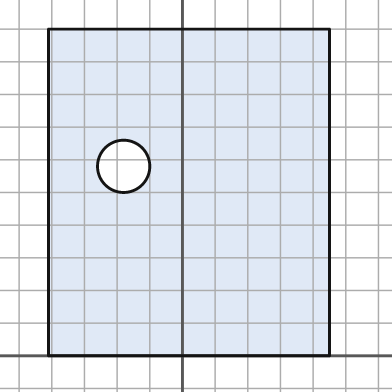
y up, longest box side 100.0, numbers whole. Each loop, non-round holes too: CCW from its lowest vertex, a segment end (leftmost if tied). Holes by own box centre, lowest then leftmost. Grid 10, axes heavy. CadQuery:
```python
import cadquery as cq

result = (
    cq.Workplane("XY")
    .moveTo(-41.0, 0.0)
    .lineTo(45.0, 0.0)
    .lineTo(45.0, 100.0)
    .lineTo(-41.0, 100.0)
    .close()
    .moveTo(-18.0, 58.0)
    .circle(8.0)
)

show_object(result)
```